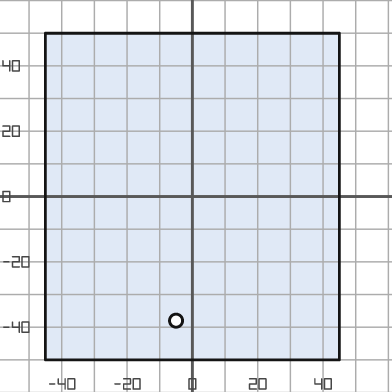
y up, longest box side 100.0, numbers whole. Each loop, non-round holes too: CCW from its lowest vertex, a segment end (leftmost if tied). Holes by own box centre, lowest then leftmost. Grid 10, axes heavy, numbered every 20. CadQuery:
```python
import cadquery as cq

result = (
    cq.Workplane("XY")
    .moveTo(-45.0, -50.0)
    .lineTo(45.0, -50.0)
    .lineTo(45.0, 50.0)
    .lineTo(-45.0, 50.0)
    .close()
    .moveTo(-5.0, -38.0)
    .circle(2.0)
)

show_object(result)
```